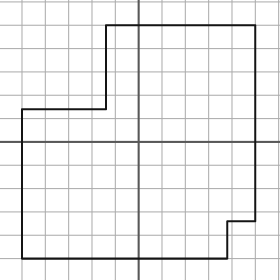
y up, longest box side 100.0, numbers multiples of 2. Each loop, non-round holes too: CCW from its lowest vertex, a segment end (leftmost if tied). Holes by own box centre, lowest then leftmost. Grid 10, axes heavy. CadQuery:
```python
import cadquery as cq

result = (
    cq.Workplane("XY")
    .moveTo(-50.0, -50.0)
    .lineTo(38.0, -50.0)
    .lineTo(38.0, -34.0)
    .lineTo(50.0, -34.0)
    .lineTo(50.0, 50.0)
    .lineTo(-14.0, 50.0)
    .lineTo(-14.0, 14.0)
    .lineTo(-50.0, 14.0)
    .close()
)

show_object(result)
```